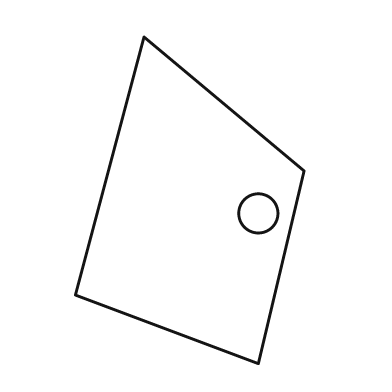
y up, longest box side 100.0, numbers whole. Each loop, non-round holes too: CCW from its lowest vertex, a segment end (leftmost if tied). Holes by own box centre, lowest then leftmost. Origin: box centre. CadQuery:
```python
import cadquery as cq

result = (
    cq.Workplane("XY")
    .moveTo(21.0, -50.0)
    .lineTo(35.0, 9.0)
    .lineTo(-14.0, 50.0)
    .lineTo(-35.0, -29.0)
    .close()
    .moveTo(21.0, -4.0)
    .circle(6.0)
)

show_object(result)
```